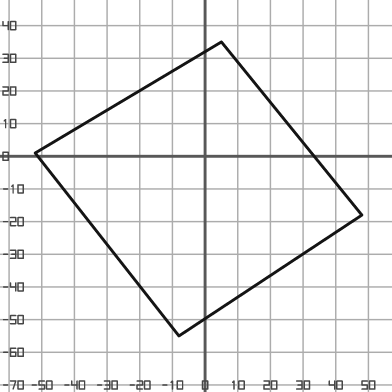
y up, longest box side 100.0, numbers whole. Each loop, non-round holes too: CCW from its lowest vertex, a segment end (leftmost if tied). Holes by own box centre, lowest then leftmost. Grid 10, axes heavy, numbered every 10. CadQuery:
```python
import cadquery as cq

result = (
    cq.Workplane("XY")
    .moveTo(-8.0, -55.0)
    .lineTo(48.0, -18.0)
    .lineTo(5.0, 35.0)
    .lineTo(-52.0, 1.0)
    .close()
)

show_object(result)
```